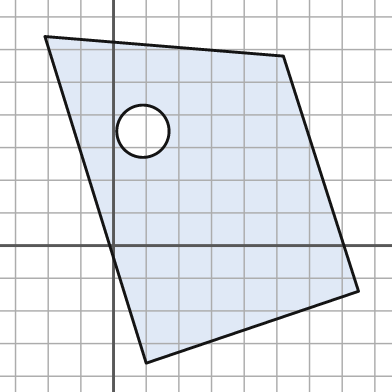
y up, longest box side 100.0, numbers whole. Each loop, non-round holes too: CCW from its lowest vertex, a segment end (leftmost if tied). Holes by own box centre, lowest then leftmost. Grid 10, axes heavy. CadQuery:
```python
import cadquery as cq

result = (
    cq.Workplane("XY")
    .moveTo(10.0, -36.0)
    .lineTo(75.0, -14.0)
    .lineTo(52.0, 58.0)
    .lineTo(-21.0, 64.0)
    .close()
    .moveTo(9.0, 35.0)
    .circle(8.0)
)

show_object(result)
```